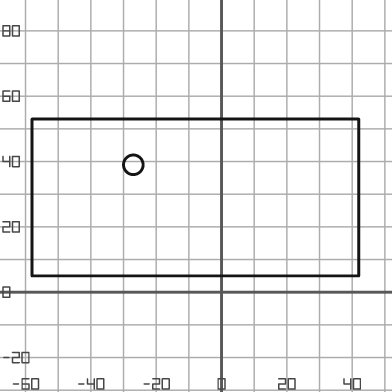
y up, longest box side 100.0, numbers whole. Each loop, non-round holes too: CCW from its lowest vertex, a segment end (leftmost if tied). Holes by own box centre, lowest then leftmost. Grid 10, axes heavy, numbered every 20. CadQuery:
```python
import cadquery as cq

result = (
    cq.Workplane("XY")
    .moveTo(-58.0, 5.0)
    .lineTo(42.0, 5.0)
    .lineTo(42.0, 53.0)
    .lineTo(-58.0, 53.0)
    .close()
    .moveTo(-27.0, 39.0)
    .circle(3.0)
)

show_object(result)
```